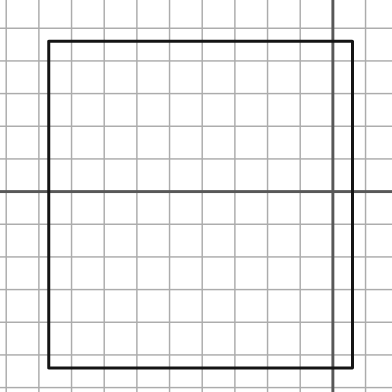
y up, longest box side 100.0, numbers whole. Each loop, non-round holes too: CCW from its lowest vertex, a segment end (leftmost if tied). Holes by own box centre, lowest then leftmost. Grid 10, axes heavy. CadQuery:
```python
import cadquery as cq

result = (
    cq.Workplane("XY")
    .moveTo(-87.0, -54.0)
    .lineTo(6.0, -54.0)
    .lineTo(6.0, 46.0)
    .lineTo(-87.0, 46.0)
    .close()
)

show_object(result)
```